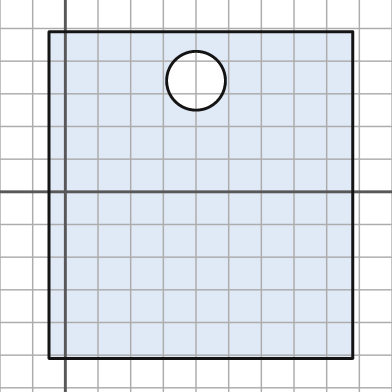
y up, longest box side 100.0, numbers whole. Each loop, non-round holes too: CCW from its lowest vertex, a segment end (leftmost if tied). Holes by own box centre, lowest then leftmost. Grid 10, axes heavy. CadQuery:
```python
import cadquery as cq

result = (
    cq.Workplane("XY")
    .moveTo(-5.0, -51.0)
    .lineTo(88.0, -51.0)
    .lineTo(88.0, 49.0)
    .lineTo(-5.0, 49.0)
    .close()
    .moveTo(40.0, 34.0)
    .circle(9.0)
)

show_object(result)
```